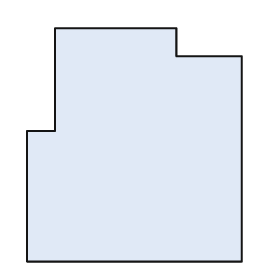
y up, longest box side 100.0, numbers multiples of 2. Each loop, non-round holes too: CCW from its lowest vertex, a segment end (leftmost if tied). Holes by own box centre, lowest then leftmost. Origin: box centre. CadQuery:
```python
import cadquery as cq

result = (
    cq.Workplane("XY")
    .moveTo(-46.0, -50.0)
    .lineTo(46.0, -50.0)
    .lineTo(46.0, 38.0)
    .lineTo(18.0, 38.0)
    .lineTo(18.0, 50.0)
    .lineTo(-34.0, 50.0)
    .lineTo(-34.0, 6.0)
    .lineTo(-46.0, 6.0)
    .close()
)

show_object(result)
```